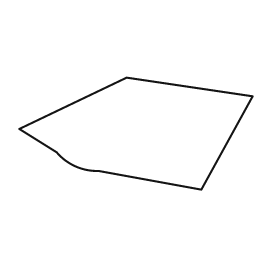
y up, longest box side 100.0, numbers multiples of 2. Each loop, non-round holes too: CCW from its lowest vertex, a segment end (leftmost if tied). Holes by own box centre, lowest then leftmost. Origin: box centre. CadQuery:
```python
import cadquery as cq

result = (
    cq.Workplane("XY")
    .moveTo(28.0, -24.0)
    .lineTo(50.0, 16.0)
    .lineTo(-4.0, 24.0)
    .lineTo(-50.0, 2.0)
    .lineTo(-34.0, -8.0)
    .threePointArc((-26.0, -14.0), (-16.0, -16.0))
    .close()
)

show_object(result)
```